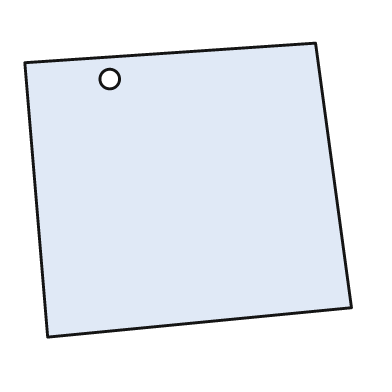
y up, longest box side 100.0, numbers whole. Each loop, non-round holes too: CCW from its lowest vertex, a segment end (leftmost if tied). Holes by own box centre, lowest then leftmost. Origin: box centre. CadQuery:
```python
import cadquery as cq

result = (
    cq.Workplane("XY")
    .moveTo(-43.0, -45.0)
    .lineTo(50.0, -36.0)
    .lineTo(39.0, 45.0)
    .lineTo(-50.0, 39.0)
    .close()
    .moveTo(-24.0, 34.0)
    .circle(3.0)
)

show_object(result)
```